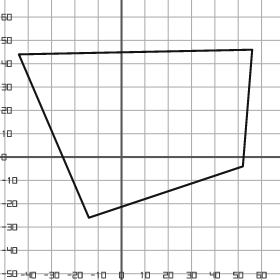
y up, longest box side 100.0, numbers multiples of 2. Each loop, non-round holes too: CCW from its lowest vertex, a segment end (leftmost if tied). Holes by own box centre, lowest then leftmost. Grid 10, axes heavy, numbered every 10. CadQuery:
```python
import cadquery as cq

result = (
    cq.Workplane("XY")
    .moveTo(-14.0, -26.0)
    .lineTo(52.0, -4.0)
    .lineTo(56.0, 46.0)
    .lineTo(-44.0, 44.0)
    .close()
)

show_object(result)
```